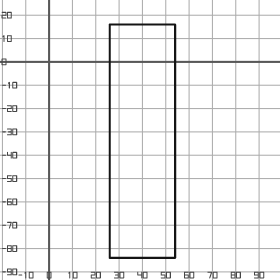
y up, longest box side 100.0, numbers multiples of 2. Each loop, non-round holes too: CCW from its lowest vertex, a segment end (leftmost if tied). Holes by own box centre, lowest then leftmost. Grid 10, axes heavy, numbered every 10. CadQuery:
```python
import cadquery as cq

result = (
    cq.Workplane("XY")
    .moveTo(26.0, -84.0)
    .lineTo(54.0, -84.0)
    .lineTo(54.0, 16.0)
    .lineTo(26.0, 16.0)
    .close()
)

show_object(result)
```